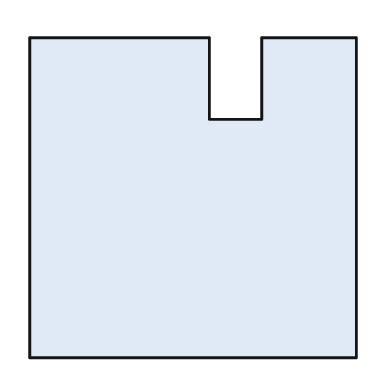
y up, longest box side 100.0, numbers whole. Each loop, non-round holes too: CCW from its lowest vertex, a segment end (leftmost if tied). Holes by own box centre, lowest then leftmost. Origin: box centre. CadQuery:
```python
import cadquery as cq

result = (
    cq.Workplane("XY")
    .moveTo(-50.0, -49.0)
    .lineTo(50.0, -49.0)
    .lineTo(50.0, 49.0)
    .lineTo(21.0, 49.0)
    .lineTo(21.0, 24.0)
    .lineTo(5.0, 24.0)
    .lineTo(5.0, 49.0)
    .lineTo(-50.0, 49.0)
    .close()
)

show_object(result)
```